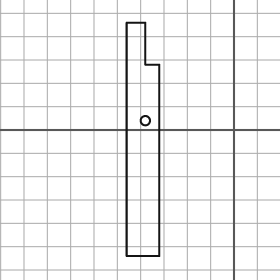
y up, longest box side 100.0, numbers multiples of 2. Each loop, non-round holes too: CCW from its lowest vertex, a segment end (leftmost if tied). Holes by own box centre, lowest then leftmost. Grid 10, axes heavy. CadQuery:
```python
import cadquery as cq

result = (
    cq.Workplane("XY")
    .moveTo(-46.0, -54.0)
    .lineTo(-32.0, -54.0)
    .lineTo(-32.0, 28.0)
    .lineTo(-38.0, 28.0)
    .lineTo(-38.0, 46.0)
    .lineTo(-46.0, 46.0)
    .close()
    .moveTo(-38.0, 4.0)
    .circle(2.0)
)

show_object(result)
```